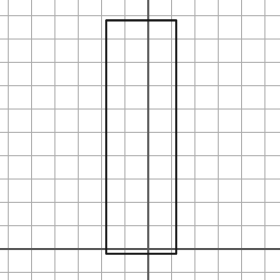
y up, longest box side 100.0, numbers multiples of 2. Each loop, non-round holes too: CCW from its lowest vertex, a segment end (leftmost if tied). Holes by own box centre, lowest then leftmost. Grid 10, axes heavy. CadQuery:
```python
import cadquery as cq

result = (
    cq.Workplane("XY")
    .moveTo(-18.0, -2.0)
    .lineTo(12.0, -2.0)
    .lineTo(12.0, 98.0)
    .lineTo(-18.0, 98.0)
    .close()
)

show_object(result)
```